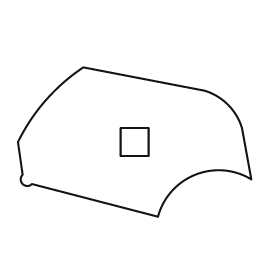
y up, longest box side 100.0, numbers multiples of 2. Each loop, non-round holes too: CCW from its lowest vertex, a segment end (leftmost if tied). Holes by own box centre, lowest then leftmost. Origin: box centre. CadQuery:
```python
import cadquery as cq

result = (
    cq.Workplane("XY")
    .moveTo(10.0, -32.0)
    .threePointArc((26.0, -14.0), (50.0, -16.0))
    .lineTo(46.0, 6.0)
    .threePointArc((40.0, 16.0), (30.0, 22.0))
    .lineTo(-22.0, 32.0)
    .threePointArc((-38.0, 18.0), (-50.0, 0.0))
    .lineTo(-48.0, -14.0)
    .threePointArc((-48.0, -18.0), (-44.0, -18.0))
    .close()
    .moveTo(-6.0, -6.0)
    .lineTo(6.0, -6.0)
    .lineTo(6.0, 6.0)
    .lineTo(-6.0, 6.0)
    .close()
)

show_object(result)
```